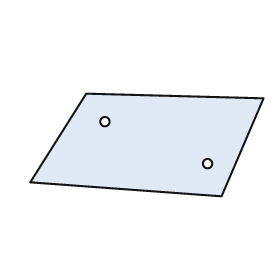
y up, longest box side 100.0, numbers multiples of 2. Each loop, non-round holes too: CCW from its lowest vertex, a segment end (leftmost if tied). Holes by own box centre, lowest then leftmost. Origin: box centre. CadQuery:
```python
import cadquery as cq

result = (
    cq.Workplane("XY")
    .moveTo(32.0, -22.0)
    .lineTo(50.0, 20.0)
    .lineTo(-26.0, 22.0)
    .lineTo(-50.0, -16.0)
    .close()
    .moveTo(26.0, -8.0)
    .circle(2.0)
    .moveTo(-18.0, 10.0)
    .circle(2.0)
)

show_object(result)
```